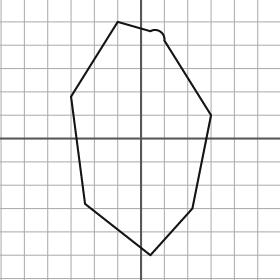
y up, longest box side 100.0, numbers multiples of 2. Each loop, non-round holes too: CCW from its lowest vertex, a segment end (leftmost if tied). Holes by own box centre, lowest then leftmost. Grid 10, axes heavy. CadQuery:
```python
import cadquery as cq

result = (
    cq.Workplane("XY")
    .moveTo(4.0, -50.0)
    .lineTo(22.0, -30.0)
    .lineTo(30.0, 10.0)
    .lineTo(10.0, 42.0)
    .threePointArc((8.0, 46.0), (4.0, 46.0))
    .lineTo(-10.0, 50.0)
    .lineTo(-30.0, 18.0)
    .lineTo(-24.0, -28.0)
    .close()
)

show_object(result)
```